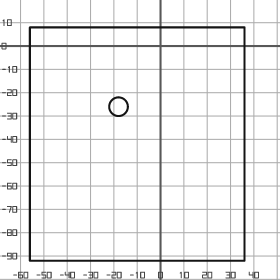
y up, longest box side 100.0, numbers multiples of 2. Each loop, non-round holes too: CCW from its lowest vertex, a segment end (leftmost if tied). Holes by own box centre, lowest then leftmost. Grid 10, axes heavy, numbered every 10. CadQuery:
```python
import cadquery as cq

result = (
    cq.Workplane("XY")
    .moveTo(-56.0, -92.0)
    .lineTo(36.0, -92.0)
    .lineTo(36.0, 8.0)
    .lineTo(-56.0, 8.0)
    .close()
    .moveTo(-18.0, -26.0)
    .circle(4.0)
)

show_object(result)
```